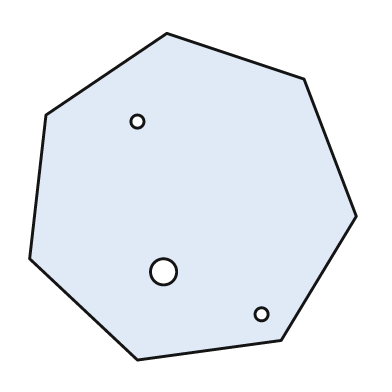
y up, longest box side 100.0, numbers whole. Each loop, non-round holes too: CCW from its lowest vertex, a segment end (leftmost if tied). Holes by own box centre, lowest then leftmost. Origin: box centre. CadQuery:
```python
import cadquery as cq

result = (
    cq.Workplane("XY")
    .moveTo(-17.0, -50.0)
    .lineTo(27.0, -44.0)
    .lineTo(50.0, -6.0)
    .lineTo(34.0, 36.0)
    .lineTo(-8.0, 50.0)
    .lineTo(-45.0, 25.0)
    .lineTo(-50.0, -19.0)
    .close()
    .moveTo(21.0, -36.0)
    .circle(2.0)
    .moveTo(-9.0, -23.0)
    .circle(4.0)
    .moveTo(-17.0, 23.0)
    .circle(2.0)
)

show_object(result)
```